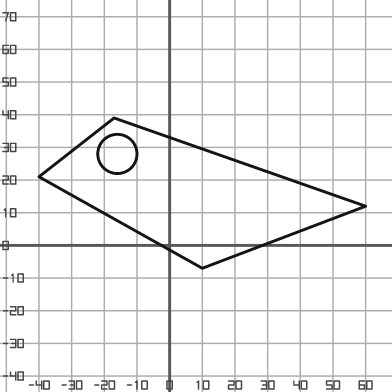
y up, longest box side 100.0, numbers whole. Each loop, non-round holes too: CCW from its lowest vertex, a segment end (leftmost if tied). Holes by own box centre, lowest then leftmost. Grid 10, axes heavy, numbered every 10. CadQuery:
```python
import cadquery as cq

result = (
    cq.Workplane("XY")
    .moveTo(10.0, -7.0)
    .lineTo(60.0, 12.0)
    .lineTo(-17.0, 39.0)
    .lineTo(-40.0, 21.0)
    .close()
    .moveTo(-16.0, 28.0)
    .circle(6.0)
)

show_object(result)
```